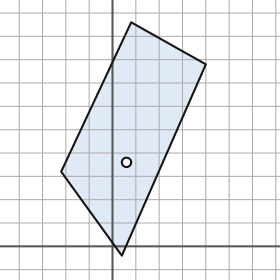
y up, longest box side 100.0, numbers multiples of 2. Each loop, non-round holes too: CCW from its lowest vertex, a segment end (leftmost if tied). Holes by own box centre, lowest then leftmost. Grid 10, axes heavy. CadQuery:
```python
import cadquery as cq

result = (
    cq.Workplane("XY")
    .moveTo(4.0, -4.0)
    .lineTo(40.0, 78.0)
    .lineTo(8.0, 96.0)
    .lineTo(-22.0, 32.0)
    .close()
    .moveTo(6.0, 36.0)
    .circle(2.0)
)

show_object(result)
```